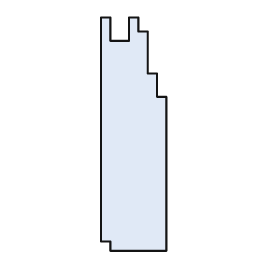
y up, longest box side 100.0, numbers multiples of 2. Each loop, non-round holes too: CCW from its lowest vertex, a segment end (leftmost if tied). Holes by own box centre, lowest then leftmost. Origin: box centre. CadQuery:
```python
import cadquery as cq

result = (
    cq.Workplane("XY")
    .moveTo(-10.0, -50.0)
    .lineTo(14.0, -50.0)
    .lineTo(14.0, 16.0)
    .lineTo(10.0, 16.0)
    .lineTo(10.0, 26.0)
    .lineTo(6.0, 26.0)
    .lineTo(6.0, 44.0)
    .lineTo(2.0, 44.0)
    .lineTo(2.0, 50.0)
    .lineTo(-2.0, 50.0)
    .lineTo(-2.0, 40.0)
    .lineTo(-10.0, 40.0)
    .lineTo(-10.0, 50.0)
    .lineTo(-14.0, 50.0)
    .lineTo(-14.0, -46.0)
    .lineTo(-10.0, -46.0)
    .close()
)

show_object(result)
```